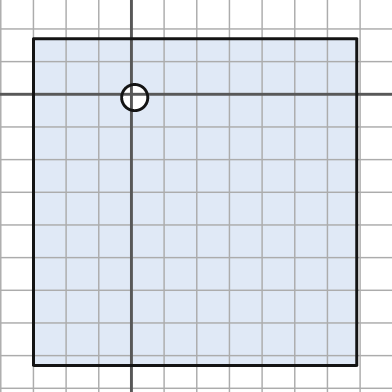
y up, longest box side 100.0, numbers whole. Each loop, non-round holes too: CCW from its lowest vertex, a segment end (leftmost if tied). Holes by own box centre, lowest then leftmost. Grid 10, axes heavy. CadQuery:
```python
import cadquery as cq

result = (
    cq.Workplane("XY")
    .moveTo(-30.0, -83.0)
    .lineTo(69.0, -83.0)
    .lineTo(69.0, 17.0)
    .lineTo(-30.0, 17.0)
    .close()
    .moveTo(1.0, -1.0)
    .circle(4.0)
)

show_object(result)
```